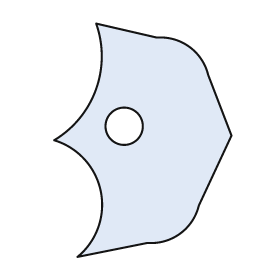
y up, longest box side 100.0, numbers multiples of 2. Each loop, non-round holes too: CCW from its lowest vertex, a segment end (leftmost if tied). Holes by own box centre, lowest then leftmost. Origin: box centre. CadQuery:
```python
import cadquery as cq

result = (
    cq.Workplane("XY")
    .moveTo(-28.0, -50.0)
    .lineTo(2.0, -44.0)
    .threePointArc((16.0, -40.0), (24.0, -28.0))
    .lineTo(38.0, 2.0)
    .lineTo(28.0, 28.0)
    .threePointArc((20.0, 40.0), (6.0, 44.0))
    .lineTo(-20.0, 50.0)
    .threePointArc((-20.0, 22.0), (-38.0, 0.0))
    .threePointArc((-18.0, -22.0), (-28.0, -50.0))
    .close()
    .moveTo(-8.0, 6.0)
    .circle(8.0)
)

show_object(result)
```